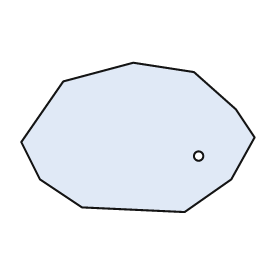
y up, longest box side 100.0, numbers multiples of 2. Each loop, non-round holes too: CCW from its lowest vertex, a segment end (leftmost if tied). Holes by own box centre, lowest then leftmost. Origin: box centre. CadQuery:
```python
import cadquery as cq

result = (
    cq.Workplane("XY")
    .moveTo(20.0, -32.0)
    .lineTo(40.0, -18.0)
    .lineTo(50.0, 0.0)
    .lineTo(42.0, 12.0)
    .lineTo(24.0, 28.0)
    .lineTo(-2.0, 32.0)
    .lineTo(-32.0, 24.0)
    .lineTo(-50.0, -2.0)
    .lineTo(-42.0, -18.0)
    .lineTo(-24.0, -30.0)
    .close()
    .moveTo(26.0, -8.0)
    .circle(2.0)
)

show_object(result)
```